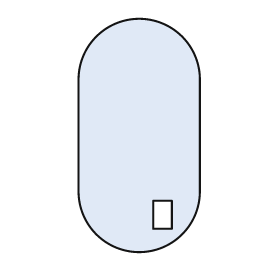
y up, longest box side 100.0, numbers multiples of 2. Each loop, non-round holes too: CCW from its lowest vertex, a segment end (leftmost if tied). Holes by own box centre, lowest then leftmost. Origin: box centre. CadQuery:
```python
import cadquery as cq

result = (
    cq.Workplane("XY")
    .moveTo(-26.0, -24.0)
    .threePointArc((0.0, -50.0), (26.0, -24.0))
    .lineTo(26.0, 24.0)
    .threePointArc((0.0, 50.0), (-26.0, 24.0))
    .close()
    .moveTo(6.0, -40.0)
    .lineTo(14.0, -40.0)
    .lineTo(14.0, -28.0)
    .lineTo(6.0, -28.0)
    .close()
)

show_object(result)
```